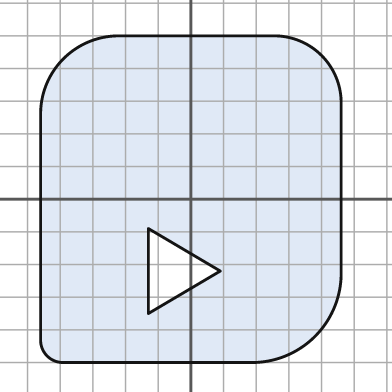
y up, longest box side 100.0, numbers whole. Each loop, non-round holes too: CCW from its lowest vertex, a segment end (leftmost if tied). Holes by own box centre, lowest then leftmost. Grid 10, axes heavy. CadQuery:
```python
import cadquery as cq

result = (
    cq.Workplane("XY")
    .moveTo(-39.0, -50.0)
    .lineTo(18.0, -50.0)
    .threePointArc((38.0, -42.0), (46.0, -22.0))
    .lineTo(46.0, 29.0)
    .threePointArc((40.0, 44.0), (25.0, 50.0))
    .lineTo(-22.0, 50.0)
    .threePointArc((-39.0, 43.0), (-46.0, 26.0))
    .lineTo(-46.0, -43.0)
    .threePointArc((-44.0, -48.0), (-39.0, -50.0))
    .close()
    .moveTo(-13.0, -35.0)
    .lineTo(9.0, -22.0)
    .lineTo(-13.0, -9.0)
    .close()
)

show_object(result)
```